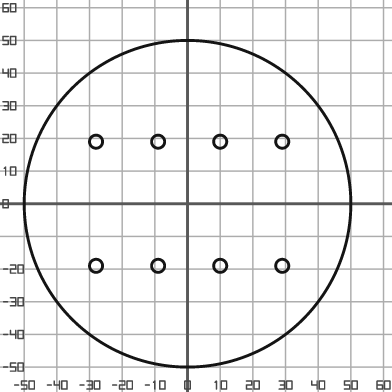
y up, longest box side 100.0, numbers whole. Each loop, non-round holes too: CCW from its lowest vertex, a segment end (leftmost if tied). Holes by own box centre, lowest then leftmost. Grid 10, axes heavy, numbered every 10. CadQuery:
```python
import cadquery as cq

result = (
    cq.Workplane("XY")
    .moveTo(0.0, 0.0)
    .circle(50.0)
    .moveTo(-28.0, -19.0)
    .circle(2.0)
    .moveTo(-9.0, -19.0)
    .circle(2.0)
    .moveTo(10.0, -19.0)
    .circle(2.0)
    .moveTo(29.0, -19.0)
    .circle(2.0)
    .moveTo(-28.0, 19.0)
    .circle(2.0)
    .moveTo(-9.0, 19.0)
    .circle(2.0)
    .moveTo(10.0, 19.0)
    .circle(2.0)
    .moveTo(29.0, 19.0)
    .circle(2.0)
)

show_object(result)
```